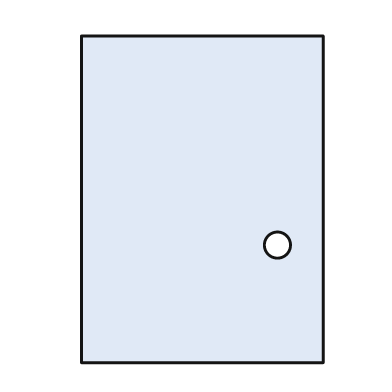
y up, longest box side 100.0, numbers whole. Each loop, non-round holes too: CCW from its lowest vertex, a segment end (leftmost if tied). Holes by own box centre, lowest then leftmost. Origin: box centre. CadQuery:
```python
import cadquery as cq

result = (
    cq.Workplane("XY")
    .moveTo(-37.0, -50.0)
    .lineTo(37.0, -50.0)
    .lineTo(37.0, 50.0)
    .lineTo(-37.0, 50.0)
    .close()
    .moveTo(23.0, -14.0)
    .circle(4.0)
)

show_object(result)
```